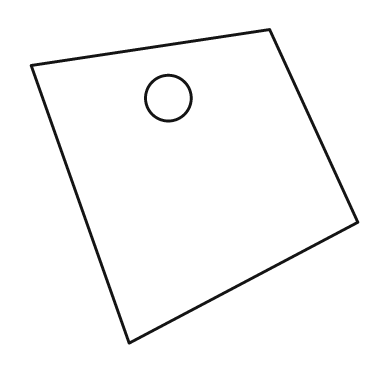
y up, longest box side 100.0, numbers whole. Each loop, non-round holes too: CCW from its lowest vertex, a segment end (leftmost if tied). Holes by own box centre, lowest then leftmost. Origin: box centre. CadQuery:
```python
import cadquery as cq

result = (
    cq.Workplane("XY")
    .moveTo(-20.0, -48.0)
    .lineTo(50.0, -11.0)
    .lineTo(23.0, 48.0)
    .lineTo(-50.0, 37.0)
    .close()
    .moveTo(-8.0, 27.0)
    .circle(7.0)
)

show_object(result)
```